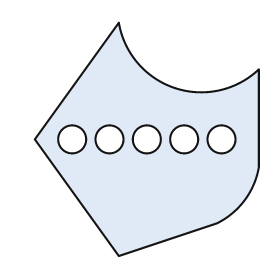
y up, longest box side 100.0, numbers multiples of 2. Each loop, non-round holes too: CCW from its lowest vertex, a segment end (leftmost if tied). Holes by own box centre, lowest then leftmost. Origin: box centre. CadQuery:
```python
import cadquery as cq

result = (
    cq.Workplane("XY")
    .moveTo(-12.0, -50.0)
    .lineTo(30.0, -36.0)
    .threePointArc((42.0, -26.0), (48.0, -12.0))
    .lineTo(48.0, 30.0)
    .threePointArc((12.0, 22.0), (-12.0, 50.0))
    .lineTo(-48.0, 0.0)
    .close()
    .moveTo(-32.0, 0.0)
    .circle(6.0)
    .moveTo(-16.0, 0.0)
    .circle(6.0)
    .moveTo(0.0, 0.0)
    .circle(6.0)
    .moveTo(16.0, 0.0)
    .circle(6.0)
    .moveTo(32.0, 0.0)
    .circle(6.0)
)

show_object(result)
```